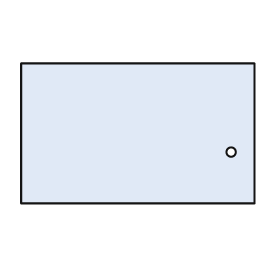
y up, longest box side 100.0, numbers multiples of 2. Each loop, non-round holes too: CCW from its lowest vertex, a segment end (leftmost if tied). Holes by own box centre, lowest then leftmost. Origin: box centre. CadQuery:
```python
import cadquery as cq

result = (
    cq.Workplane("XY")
    .moveTo(-50.0, -30.0)
    .lineTo(50.0, -30.0)
    .lineTo(50.0, 30.0)
    .lineTo(-50.0, 30.0)
    .close()
    .moveTo(40.0, -8.0)
    .circle(2.0)
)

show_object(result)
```